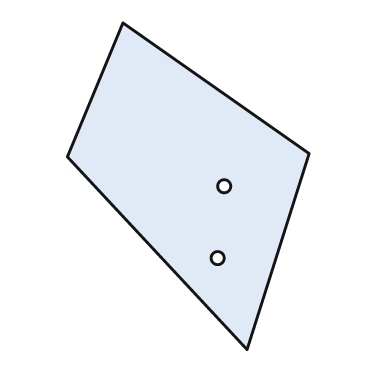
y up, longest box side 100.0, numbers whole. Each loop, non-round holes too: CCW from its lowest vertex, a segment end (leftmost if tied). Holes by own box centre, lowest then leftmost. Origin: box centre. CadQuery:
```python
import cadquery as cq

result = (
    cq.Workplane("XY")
    .moveTo(18.0, -50.0)
    .lineTo(37.0, 10.0)
    .lineTo(-20.0, 50.0)
    .lineTo(-37.0, 9.0)
    .close()
    .moveTo(9.0, -22.0)
    .circle(2.0)
    .moveTo(11.0, 0.0)
    .circle(2.0)
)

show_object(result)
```